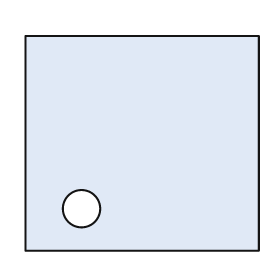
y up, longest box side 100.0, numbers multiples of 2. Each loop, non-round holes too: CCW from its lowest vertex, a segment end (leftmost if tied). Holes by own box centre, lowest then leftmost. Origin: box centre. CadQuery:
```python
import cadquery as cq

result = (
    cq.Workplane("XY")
    .moveTo(-50.0, -46.0)
    .lineTo(50.0, -46.0)
    .lineTo(50.0, 46.0)
    .lineTo(-50.0, 46.0)
    .close()
    .moveTo(-26.0, -28.0)
    .circle(8.0)
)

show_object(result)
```